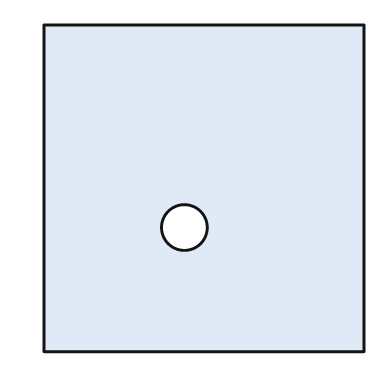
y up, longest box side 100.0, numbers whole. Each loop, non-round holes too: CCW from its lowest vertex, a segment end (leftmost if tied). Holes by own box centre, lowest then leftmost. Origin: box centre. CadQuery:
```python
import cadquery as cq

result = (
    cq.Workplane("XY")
    .moveTo(-49.0, -50.0)
    .lineTo(49.0, -50.0)
    .lineTo(49.0, 50.0)
    .lineTo(-49.0, 50.0)
    .close()
    .moveTo(-6.0, -12.0)
    .circle(7.0)
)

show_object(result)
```